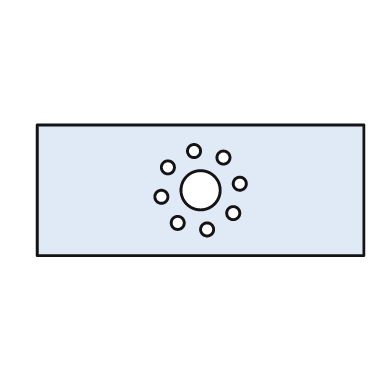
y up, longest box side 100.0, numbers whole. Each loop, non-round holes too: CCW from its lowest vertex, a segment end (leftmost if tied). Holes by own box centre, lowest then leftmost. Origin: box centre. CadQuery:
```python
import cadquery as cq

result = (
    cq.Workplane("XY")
    .moveTo(-50.0, -20.0)
    .lineTo(50.0, -20.0)
    .lineTo(50.0, 20.0)
    .lineTo(-50.0, 20.0)
    .close()
    .moveTo(2.0, -12.0)
    .circle(2.0)
    .moveTo(-7.0, -10.0)
    .circle(2.0)
    .moveTo(10.0, -7.0)
    .circle(2.0)
    .moveTo(-12.0, -2.0)
    .circle(2.0)
    .moveTo(0.0, 0.0)
    .circle(6.0)
    .moveTo(12.0, 2.0)
    .circle(2.0)
    .moveTo(-10.0, 7.0)
    .circle(2.0)
    .moveTo(7.0, 10.0)
    .circle(2.0)
    .moveTo(-2.0, 12.0)
    .circle(2.0)
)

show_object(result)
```